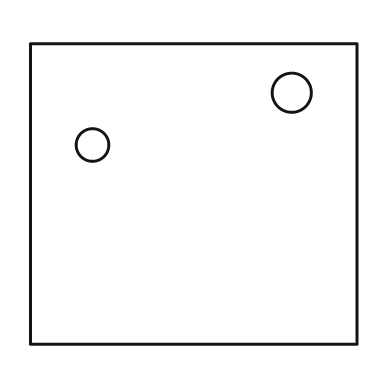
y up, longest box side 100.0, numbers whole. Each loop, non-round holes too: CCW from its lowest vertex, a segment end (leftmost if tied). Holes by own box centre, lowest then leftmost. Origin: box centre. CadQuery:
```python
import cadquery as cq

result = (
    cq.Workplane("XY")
    .moveTo(-50.0, -46.0)
    .lineTo(50.0, -46.0)
    .lineTo(50.0, 46.0)
    .lineTo(-50.0, 46.0)
    .close()
    .moveTo(-31.0, 15.0)
    .circle(5.0)
    .moveTo(30.0, 31.0)
    .circle(6.0)
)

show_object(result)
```